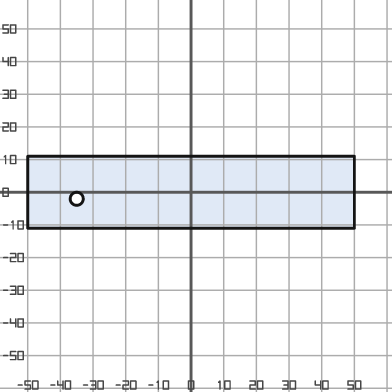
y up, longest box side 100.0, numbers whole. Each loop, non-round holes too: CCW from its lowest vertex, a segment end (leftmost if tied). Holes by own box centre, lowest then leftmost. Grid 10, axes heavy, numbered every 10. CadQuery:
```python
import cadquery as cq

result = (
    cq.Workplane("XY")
    .moveTo(-50.0, -11.0)
    .lineTo(50.0, -11.0)
    .lineTo(50.0, 11.0)
    .lineTo(-50.0, 11.0)
    .close()
    .moveTo(-35.0, -2.0)
    .circle(2.0)
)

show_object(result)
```